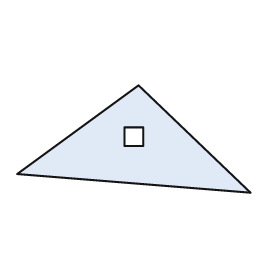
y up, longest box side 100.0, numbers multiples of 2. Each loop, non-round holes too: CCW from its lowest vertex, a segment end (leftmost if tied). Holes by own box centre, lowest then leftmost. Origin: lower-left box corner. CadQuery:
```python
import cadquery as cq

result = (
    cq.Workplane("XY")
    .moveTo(100.0, 0.0)
    .lineTo(52.0, 46.0)
    .lineTo(0.0, 8.0)
    .close()
    .moveTo(46.0, 20.0)
    .lineTo(54.0, 20.0)
    .lineTo(54.0, 28.0)
    .lineTo(46.0, 28.0)
    .close()
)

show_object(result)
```